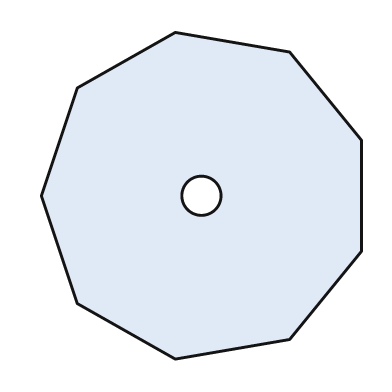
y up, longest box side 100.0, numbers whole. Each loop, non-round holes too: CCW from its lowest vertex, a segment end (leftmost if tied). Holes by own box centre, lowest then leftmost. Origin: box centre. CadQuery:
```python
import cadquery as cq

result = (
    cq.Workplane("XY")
    .moveTo(-8.0, -50.0)
    .lineTo(27.0, -44.0)
    .lineTo(49.0, -17.0)
    .lineTo(49.0, 17.0)
    .lineTo(27.0, 44.0)
    .lineTo(-8.0, 50.0)
    .lineTo(-38.0, 33.0)
    .lineTo(-49.0, 0.0)
    .lineTo(-38.0, -33.0)
    .close()
    .moveTo(0.0, 0.0)
    .circle(6.0)
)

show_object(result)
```